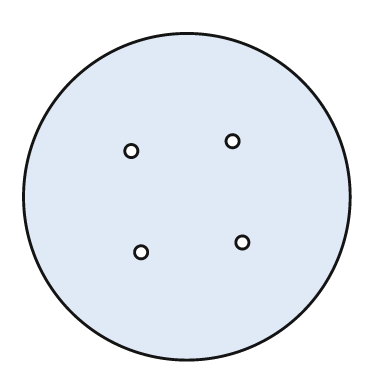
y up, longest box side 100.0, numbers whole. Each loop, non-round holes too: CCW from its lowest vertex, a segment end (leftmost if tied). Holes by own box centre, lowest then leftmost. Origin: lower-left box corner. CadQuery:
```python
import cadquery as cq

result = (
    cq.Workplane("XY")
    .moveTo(50.0, 50.0)
    .circle(50.0)
    .moveTo(36.0, 33.0)
    .circle(2.0)
    .moveTo(67.0, 36.0)
    .circle(2.0)
    .moveTo(33.0, 64.0)
    .circle(2.0)
    .moveTo(64.0, 67.0)
    .circle(2.0)
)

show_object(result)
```